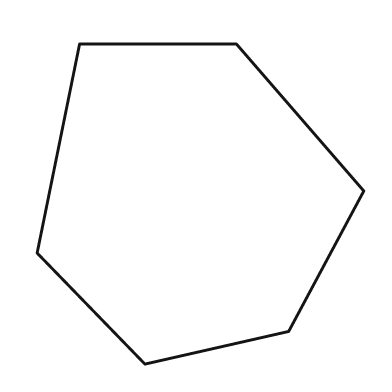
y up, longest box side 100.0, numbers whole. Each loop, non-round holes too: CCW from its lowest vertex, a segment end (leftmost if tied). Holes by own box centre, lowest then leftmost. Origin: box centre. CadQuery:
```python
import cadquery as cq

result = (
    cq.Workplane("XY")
    .moveTo(-17.0, -49.0)
    .lineTo(27.0, -39.0)
    .lineTo(50.0, 4.0)
    .lineTo(11.0, 49.0)
    .lineTo(-37.0, 49.0)
    .lineTo(-50.0, -15.0)
    .close()
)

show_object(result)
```